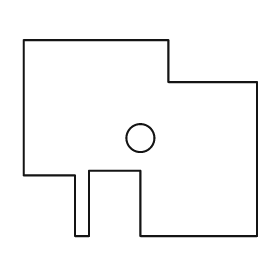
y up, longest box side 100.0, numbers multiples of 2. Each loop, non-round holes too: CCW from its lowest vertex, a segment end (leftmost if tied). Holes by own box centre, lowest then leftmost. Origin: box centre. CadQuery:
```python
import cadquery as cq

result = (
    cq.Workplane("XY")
    .moveTo(-28.0, -42.0)
    .lineTo(-22.0, -42.0)
    .lineTo(-22.0, -14.0)
    .lineTo(0.0, -14.0)
    .lineTo(0.0, -42.0)
    .lineTo(50.0, -42.0)
    .lineTo(50.0, 24.0)
    .lineTo(12.0, 24.0)
    .lineTo(12.0, 42.0)
    .lineTo(-50.0, 42.0)
    .lineTo(-50.0, -16.0)
    .lineTo(-28.0, -16.0)
    .close()
    .moveTo(0.0, 0.0)
    .circle(6.0)
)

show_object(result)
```